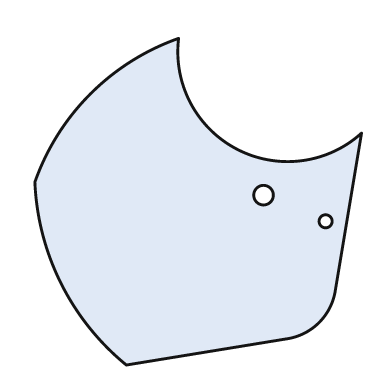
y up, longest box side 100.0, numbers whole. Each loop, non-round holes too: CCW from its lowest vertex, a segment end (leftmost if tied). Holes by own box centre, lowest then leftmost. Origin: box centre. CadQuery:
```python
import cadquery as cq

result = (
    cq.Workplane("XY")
    .moveTo(-22.0, -50.0)
    .lineTo(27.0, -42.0)
    .threePointArc((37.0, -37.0), (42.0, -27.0))
    .lineTo(50.0, 21.0)
    .threePointArc((12.0, 16.0), (-6.0, 50.0))
    .threePointArc((-33.0, 33.0), (-50.0, 6.0))
    .threePointArc((-42.0, -25.0), (-22.0, -50.0))
    .close()
    .moveTo(39.0, -6.0)
    .circle(2.0)
    .moveTo(20.0, 2.0)
    .circle(3.0)
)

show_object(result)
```